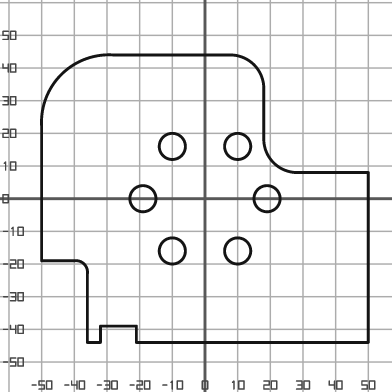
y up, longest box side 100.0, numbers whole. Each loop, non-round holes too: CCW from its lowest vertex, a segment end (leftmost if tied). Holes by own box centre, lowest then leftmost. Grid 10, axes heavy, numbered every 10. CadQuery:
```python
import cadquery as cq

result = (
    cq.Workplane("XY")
    .moveTo(-36.0, -44.0)
    .lineTo(-32.0, -44.0)
    .lineTo(-32.0, -39.0)
    .lineTo(-21.0, -39.0)
    .lineTo(-21.0, -44.0)
    .lineTo(50.0, -44.0)
    .lineTo(50.0, 8.0)
    .lineTo(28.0, 8.0)
    .threePointArc((21.0, 11.0), (18.0, 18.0))
    .lineTo(18.0, 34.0)
    .threePointArc((15.0, 41.0), (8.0, 44.0))
    .lineTo(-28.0, 44.0)
    .threePointArc((-44.0, 38.0), (-50.0, 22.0))
    .lineTo(-50.0, -19.0)
    .lineTo(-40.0, -19.0)
    .threePointArc((-37.0, -20.0), (-36.0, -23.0))
    .close()
    .moveTo(-10.0, -16.0)
    .circle(4.0)
    .moveTo(10.0, -16.0)
    .circle(4.0)
    .moveTo(-19.0, 0.0)
    .circle(4.0)
    .moveTo(19.0, 0.0)
    .circle(4.0)
    .moveTo(-10.0, 16.0)
    .circle(4.0)
    .moveTo(10.0, 16.0)
    .circle(4.0)
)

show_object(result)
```